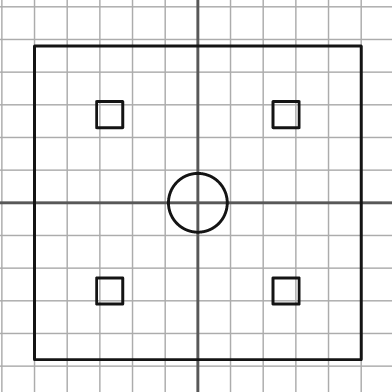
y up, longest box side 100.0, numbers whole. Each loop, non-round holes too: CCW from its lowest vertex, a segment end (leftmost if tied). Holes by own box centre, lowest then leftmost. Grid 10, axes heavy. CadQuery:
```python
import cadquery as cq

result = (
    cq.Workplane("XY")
    .moveTo(-50.0, -48.0)
    .lineTo(50.0, -48.0)
    .lineTo(50.0, 48.0)
    .lineTo(-50.0, 48.0)
    .close()
    .moveTo(-31.0, -31.0)
    .lineTo(-23.0, -31.0)
    .lineTo(-23.0, -23.0)
    .lineTo(-31.0, -23.0)
    .close()
    .moveTo(23.0, -31.0)
    .lineTo(31.0, -31.0)
    .lineTo(31.0, -23.0)
    .lineTo(23.0, -23.0)
    .close()
    .moveTo(0.0, 0.0)
    .circle(9.0)
    .moveTo(-31.0, 23.0)
    .lineTo(-23.0, 23.0)
    .lineTo(-23.0, 31.0)
    .lineTo(-31.0, 31.0)
    .close()
    .moveTo(23.0, 23.0)
    .lineTo(31.0, 23.0)
    .lineTo(31.0, 31.0)
    .lineTo(23.0, 31.0)
    .close()
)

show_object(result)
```